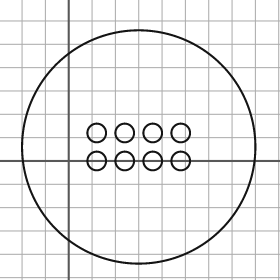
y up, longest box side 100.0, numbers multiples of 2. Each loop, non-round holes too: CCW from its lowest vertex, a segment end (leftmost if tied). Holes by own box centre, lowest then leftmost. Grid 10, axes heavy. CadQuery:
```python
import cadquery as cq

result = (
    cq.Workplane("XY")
    .moveTo(30.0, 6.0)
    .circle(50.0)
    .moveTo(12.0, 0.0)
    .circle(4.0)
    .moveTo(24.0, 0.0)
    .circle(4.0)
    .moveTo(36.0, 0.0)
    .circle(4.0)
    .moveTo(48.0, 0.0)
    .circle(4.0)
    .moveTo(12.0, 12.0)
    .circle(4.0)
    .moveTo(24.0, 12.0)
    .circle(4.0)
    .moveTo(36.0, 12.0)
    .circle(4.0)
    .moveTo(48.0, 12.0)
    .circle(4.0)
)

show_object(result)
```